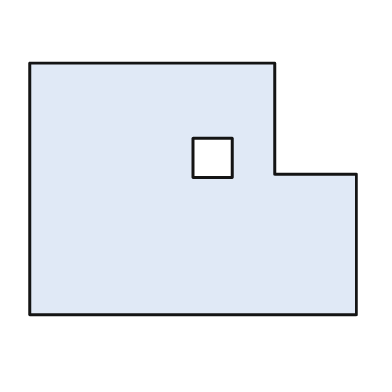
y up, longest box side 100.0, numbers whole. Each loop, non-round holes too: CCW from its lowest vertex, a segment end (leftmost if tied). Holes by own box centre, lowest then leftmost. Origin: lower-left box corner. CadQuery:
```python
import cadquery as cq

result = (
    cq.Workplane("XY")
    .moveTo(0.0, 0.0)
    .lineTo(100.0, 0.0)
    .lineTo(100.0, 43.0)
    .lineTo(75.0, 43.0)
    .lineTo(75.0, 77.0)
    .lineTo(0.0, 77.0)
    .close()
    .moveTo(50.0, 42.0)
    .lineTo(62.0, 42.0)
    .lineTo(62.0, 54.0)
    .lineTo(50.0, 54.0)
    .close()
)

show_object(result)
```